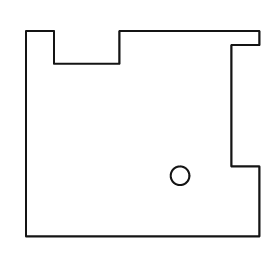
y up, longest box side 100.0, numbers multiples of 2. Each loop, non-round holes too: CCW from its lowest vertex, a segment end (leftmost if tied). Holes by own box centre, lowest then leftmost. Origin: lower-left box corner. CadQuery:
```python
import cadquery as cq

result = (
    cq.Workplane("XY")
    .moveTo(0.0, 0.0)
    .lineTo(100.0, 0.0)
    .lineTo(100.0, 30.0)
    .lineTo(88.0, 30.0)
    .lineTo(88.0, 82.0)
    .lineTo(100.0, 82.0)
    .lineTo(100.0, 88.0)
    .lineTo(40.0, 88.0)
    .lineTo(40.0, 74.0)
    .lineTo(12.0, 74.0)
    .lineTo(12.0, 88.0)
    .lineTo(0.0, 88.0)
    .close()
    .moveTo(66.0, 26.0)
    .circle(4.0)
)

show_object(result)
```